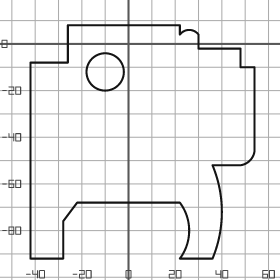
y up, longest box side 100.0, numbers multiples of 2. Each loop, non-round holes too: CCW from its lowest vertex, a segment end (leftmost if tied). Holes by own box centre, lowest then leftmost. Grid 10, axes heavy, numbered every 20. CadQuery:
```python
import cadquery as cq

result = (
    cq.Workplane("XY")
    .moveTo(-42.0, -92.0)
    .lineTo(-28.0, -92.0)
    .lineTo(-28.0, -76.0)
    .lineTo(-22.0, -68.0)
    .lineTo(22.0, -68.0)
    .threePointArc((26.0, -80.0), (22.0, -92.0))
    .lineTo(36.0, -92.0)
    .threePointArc((40.0, -72.0), (36.0, -52.0))
    .lineTo(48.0, -52.0)
    .threePointArc((52.0, -50.0), (54.0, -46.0))
    .lineTo(54.0, -10.0)
    .lineTo(48.0, -10.0)
    .lineTo(48.0, -2.0)
    .lineTo(30.0, -2.0)
    .lineTo(30.0, 4.0)
    .threePointArc((26.0, 6.0), (22.0, 4.0))
    .lineTo(22.0, 8.0)
    .lineTo(-26.0, 8.0)
    .lineTo(-26.0, -8.0)
    .lineTo(-42.0, -8.0)
    .close()
    .moveTo(-10.0, -12.0)
    .circle(8.0)
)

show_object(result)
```